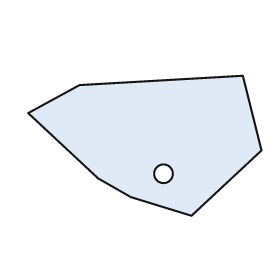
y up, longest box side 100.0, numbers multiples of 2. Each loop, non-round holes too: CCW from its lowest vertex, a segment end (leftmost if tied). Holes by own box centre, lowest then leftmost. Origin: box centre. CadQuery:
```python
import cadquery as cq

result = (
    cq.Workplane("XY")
    .moveTo(20.0, -30.0)
    .lineTo(50.0, -2.0)
    .lineTo(42.0, 30.0)
    .lineTo(-28.0, 26.0)
    .lineTo(-50.0, 14.0)
    .lineTo(-20.0, -14.0)
    .lineTo(-6.0, -22.0)
    .close()
    .moveTo(8.0, -12.0)
    .circle(4.0)
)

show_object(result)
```